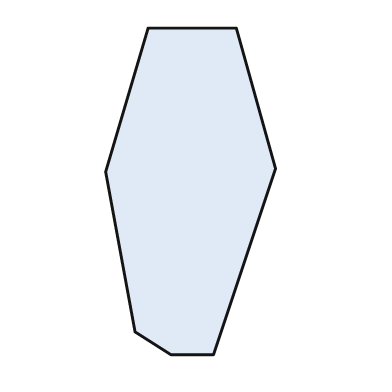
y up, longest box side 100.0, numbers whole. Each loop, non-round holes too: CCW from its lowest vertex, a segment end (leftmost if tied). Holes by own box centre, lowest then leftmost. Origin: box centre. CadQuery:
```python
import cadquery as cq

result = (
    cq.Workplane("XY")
    .moveTo(-6.0, -50.0)
    .lineTo(7.0, -50.0)
    .lineTo(26.0, 7.0)
    .lineTo(14.0, 50.0)
    .lineTo(-13.0, 50.0)
    .lineTo(-26.0, 6.0)
    .lineTo(-17.0, -43.0)
    .close()
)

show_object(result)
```